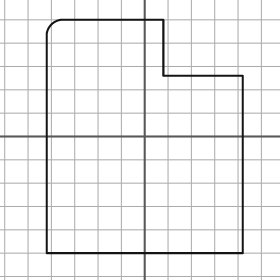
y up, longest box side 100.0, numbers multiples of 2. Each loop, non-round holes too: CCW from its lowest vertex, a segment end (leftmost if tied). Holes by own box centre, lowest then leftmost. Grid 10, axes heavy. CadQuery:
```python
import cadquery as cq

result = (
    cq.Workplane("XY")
    .moveTo(-42.0, -50.0)
    .lineTo(42.0, -50.0)
    .lineTo(42.0, 26.0)
    .lineTo(8.0, 26.0)
    .lineTo(8.0, 50.0)
    .lineTo(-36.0, 50.0)
    .threePointArc((-40.0, 48.0), (-42.0, 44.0))
    .close()
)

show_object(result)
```